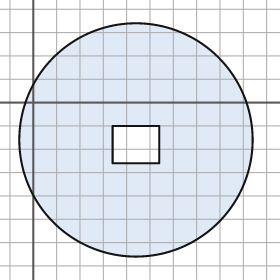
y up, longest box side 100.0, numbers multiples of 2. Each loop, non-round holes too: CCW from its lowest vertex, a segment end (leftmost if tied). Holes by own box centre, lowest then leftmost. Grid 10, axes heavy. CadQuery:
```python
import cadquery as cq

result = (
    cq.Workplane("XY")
    .moveTo(44.0, -16.0)
    .circle(50.0)
    .moveTo(34.0, -26.0)
    .lineTo(54.0, -26.0)
    .lineTo(54.0, -10.0)
    .lineTo(34.0, -10.0)
    .close()
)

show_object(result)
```